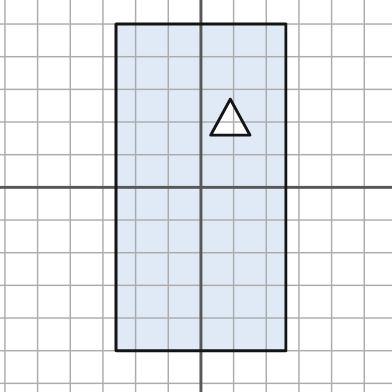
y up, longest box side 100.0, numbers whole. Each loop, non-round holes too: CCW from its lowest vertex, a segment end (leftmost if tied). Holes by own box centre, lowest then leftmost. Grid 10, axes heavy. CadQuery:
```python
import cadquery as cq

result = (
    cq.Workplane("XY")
    .moveTo(-26.0, -50.0)
    .lineTo(26.0, -50.0)
    .lineTo(26.0, 50.0)
    .lineTo(-26.0, 50.0)
    .close()
    .moveTo(3.0, 16.0)
    .lineTo(15.0, 16.0)
    .lineTo(9.0, 27.0)
    .close()
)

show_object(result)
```